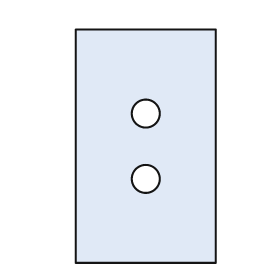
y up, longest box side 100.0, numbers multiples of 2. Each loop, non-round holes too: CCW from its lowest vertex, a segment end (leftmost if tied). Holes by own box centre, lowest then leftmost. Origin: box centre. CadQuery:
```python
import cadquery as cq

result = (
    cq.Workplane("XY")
    .moveTo(-30.0, -50.0)
    .lineTo(30.0, -50.0)
    .lineTo(30.0, 50.0)
    .lineTo(-30.0, 50.0)
    .close()
    .moveTo(0.0, -14.0)
    .circle(6.0)
    .moveTo(0.0, 14.0)
    .circle(6.0)
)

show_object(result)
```